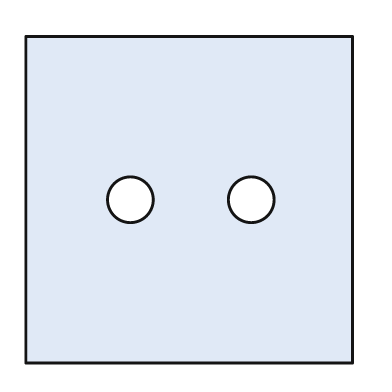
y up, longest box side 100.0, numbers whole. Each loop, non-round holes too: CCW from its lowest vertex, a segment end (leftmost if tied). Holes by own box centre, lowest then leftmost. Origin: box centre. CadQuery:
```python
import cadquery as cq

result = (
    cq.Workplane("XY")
    .moveTo(-50.0, -50.0)
    .lineTo(50.0, -50.0)
    .lineTo(50.0, 50.0)
    .lineTo(-50.0, 50.0)
    .close()
    .moveTo(-18.0, 0.0)
    .circle(7.0)
    .moveTo(19.0, 0.0)
    .circle(7.0)
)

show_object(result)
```